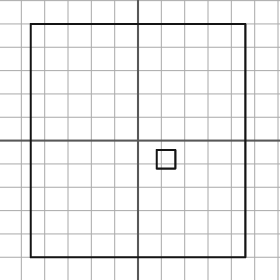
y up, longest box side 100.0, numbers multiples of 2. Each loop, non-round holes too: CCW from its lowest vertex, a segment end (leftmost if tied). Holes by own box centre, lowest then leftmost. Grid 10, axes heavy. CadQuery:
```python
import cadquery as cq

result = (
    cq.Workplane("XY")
    .moveTo(-46.0, -50.0)
    .lineTo(46.0, -50.0)
    .lineTo(46.0, 50.0)
    .lineTo(-46.0, 50.0)
    .close()
    .moveTo(8.0, -12.0)
    .lineTo(16.0, -12.0)
    .lineTo(16.0, -4.0)
    .lineTo(8.0, -4.0)
    .close()
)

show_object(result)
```